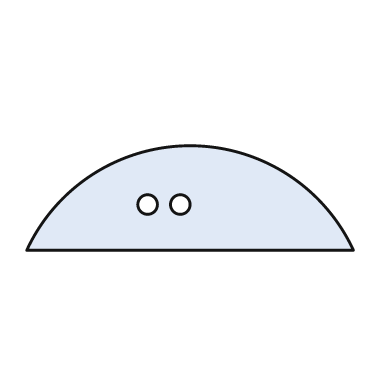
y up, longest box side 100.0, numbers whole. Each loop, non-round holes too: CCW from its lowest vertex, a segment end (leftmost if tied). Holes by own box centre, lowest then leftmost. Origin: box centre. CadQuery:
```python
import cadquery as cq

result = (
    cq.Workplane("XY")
    .moveTo(-50.0, -16.0)
    .lineTo(50.0, -16.0)
    .threePointArc((0.0, 16.0), (-50.0, -16.0))
    .close()
    .moveTo(-13.0, -2.0)
    .circle(3.0)
    .moveTo(-3.0, -2.0)
    .circle(3.0)
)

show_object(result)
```